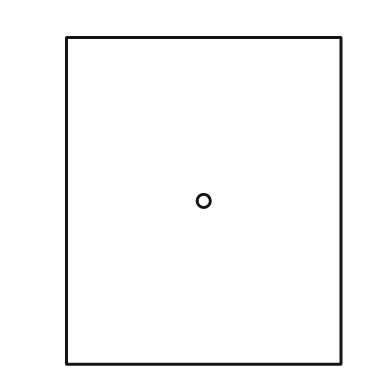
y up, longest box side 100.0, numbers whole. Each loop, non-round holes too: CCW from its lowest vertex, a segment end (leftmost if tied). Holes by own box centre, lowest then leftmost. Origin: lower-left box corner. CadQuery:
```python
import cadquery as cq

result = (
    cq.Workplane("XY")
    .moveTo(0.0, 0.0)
    .lineTo(84.0, 0.0)
    .lineTo(84.0, 100.0)
    .lineTo(0.0, 100.0)
    .close()
    .moveTo(42.0, 50.0)
    .circle(2.0)
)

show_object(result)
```